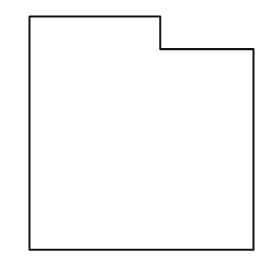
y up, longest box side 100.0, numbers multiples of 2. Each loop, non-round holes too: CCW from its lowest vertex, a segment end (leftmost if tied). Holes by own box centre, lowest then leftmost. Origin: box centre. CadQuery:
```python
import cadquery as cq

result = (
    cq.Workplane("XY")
    .moveTo(-48.0, -50.0)
    .lineTo(48.0, -50.0)
    .lineTo(48.0, 36.0)
    .lineTo(8.0, 36.0)
    .lineTo(8.0, 50.0)
    .lineTo(-48.0, 50.0)
    .close()
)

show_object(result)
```